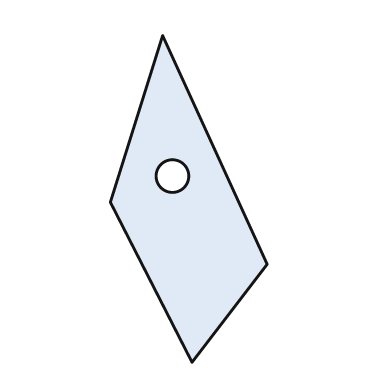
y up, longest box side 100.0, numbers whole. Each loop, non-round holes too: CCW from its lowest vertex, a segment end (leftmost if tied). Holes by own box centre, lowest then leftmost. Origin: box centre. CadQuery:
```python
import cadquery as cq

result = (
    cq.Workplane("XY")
    .moveTo(1.0, -50.0)
    .lineTo(24.0, -20.0)
    .lineTo(-8.0, 50.0)
    .lineTo(-24.0, -1.0)
    .close()
    .moveTo(-5.0, 7.0)
    .circle(5.0)
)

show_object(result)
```